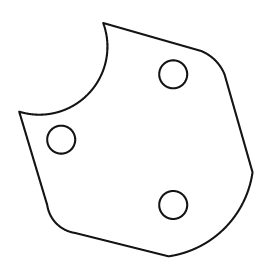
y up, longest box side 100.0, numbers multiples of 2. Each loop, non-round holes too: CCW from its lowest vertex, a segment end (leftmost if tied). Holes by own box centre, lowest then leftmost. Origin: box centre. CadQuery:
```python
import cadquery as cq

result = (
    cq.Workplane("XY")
    .moveTo(14.0, -50.0)
    .threePointArc((38.0, -38.0), (50.0, -14.0))
    .lineTo(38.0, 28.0)
    .threePointArc((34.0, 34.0), (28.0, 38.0))
    .lineTo(-14.0, 50.0)
    .threePointArc((-20.0, 20.0), (-50.0, 12.0))
    .lineTo(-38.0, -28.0)
    .threePointArc((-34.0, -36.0), (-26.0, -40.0))
    .close()
    .moveTo(16.0, -28.0)
    .circle(6.0)
    .moveTo(-32.0, 0.0)
    .circle(6.0)
    .moveTo(16.0, 28.0)
    .circle(6.0)
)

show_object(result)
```